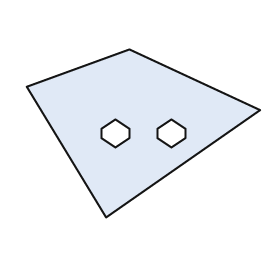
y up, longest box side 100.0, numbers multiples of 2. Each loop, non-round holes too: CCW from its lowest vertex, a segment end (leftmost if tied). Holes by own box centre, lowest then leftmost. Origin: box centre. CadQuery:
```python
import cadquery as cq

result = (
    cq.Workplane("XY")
    .moveTo(-16.0, -36.0)
    .lineTo(50.0, 10.0)
    .lineTo(-6.0, 36.0)
    .lineTo(-50.0, 20.0)
    .close()
    .moveTo(-12.0, -6.0)
    .lineTo(-6.0, -2.0)
    .lineTo(-6.0, 2.0)
    .lineTo(-12.0, 6.0)
    .lineTo(-18.0, 2.0)
    .lineTo(-18.0, -2.0)
    .close()
    .moveTo(12.0, -6.0)
    .lineTo(18.0, -2.0)
    .lineTo(18.0, 2.0)
    .lineTo(12.0, 6.0)
    .lineTo(6.0, 2.0)
    .lineTo(6.0, -2.0)
    .close()
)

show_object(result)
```